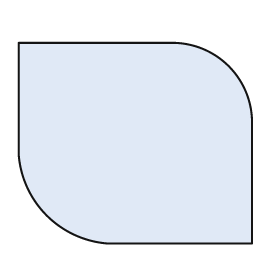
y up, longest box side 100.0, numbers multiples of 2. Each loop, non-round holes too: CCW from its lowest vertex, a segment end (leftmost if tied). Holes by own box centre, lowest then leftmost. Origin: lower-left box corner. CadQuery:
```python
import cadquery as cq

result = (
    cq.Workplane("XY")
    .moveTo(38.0, 0.0)
    .lineTo(100.0, 0.0)
    .lineTo(100.0, 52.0)
    .threePointArc((90.0, 76.0), (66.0, 86.0))
    .lineTo(0.0, 86.0)
    .lineTo(0.0, 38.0)
    .threePointArc((12.0, 12.0), (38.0, 0.0))
    .close()
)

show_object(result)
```